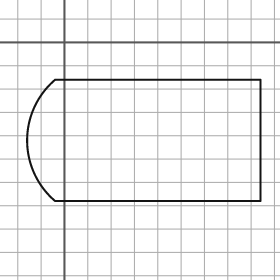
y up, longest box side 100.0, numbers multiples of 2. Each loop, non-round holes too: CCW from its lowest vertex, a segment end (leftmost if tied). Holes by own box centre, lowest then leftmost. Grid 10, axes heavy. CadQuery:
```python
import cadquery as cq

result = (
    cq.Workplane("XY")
    .moveTo(-4.0, -68.0)
    .lineTo(84.0, -68.0)
    .lineTo(84.0, -16.0)
    .lineTo(-4.0, -16.0)
    .threePointArc((-16.0, -42.0), (-4.0, -68.0))
    .close()
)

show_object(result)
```